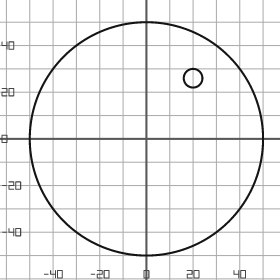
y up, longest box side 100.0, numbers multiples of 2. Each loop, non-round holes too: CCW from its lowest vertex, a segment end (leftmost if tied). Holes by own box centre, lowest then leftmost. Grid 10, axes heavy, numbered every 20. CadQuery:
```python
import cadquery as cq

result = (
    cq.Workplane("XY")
    .moveTo(0.0, 0.0)
    .circle(50.0)
    .moveTo(20.0, 26.0)
    .circle(4.0)
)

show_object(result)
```